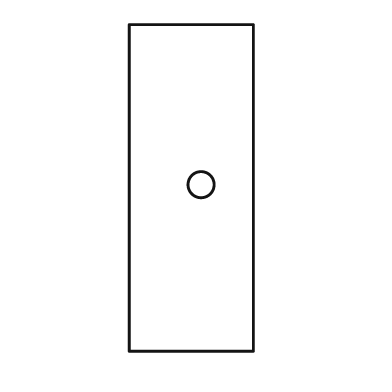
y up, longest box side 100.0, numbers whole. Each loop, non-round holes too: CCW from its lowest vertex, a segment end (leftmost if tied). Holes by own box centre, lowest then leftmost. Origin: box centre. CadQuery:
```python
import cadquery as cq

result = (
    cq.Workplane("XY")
    .moveTo(-19.0, -50.0)
    .lineTo(19.0, -50.0)
    .lineTo(19.0, 50.0)
    .lineTo(-19.0, 50.0)
    .close()
    .moveTo(3.0, 1.0)
    .circle(4.0)
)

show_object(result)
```